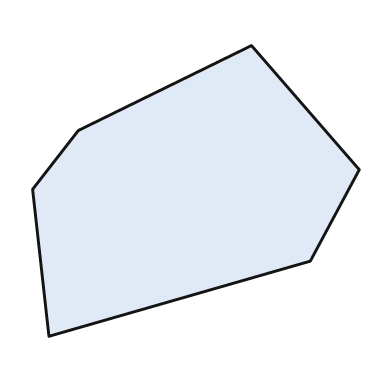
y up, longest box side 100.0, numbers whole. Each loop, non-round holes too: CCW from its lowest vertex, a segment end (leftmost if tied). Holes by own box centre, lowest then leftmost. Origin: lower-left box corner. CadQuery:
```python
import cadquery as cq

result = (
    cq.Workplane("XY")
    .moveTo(5.0, 0.0)
    .lineTo(85.0, 23.0)
    .lineTo(100.0, 51.0)
    .lineTo(67.0, 89.0)
    .lineTo(14.0, 63.0)
    .lineTo(0.0, 45.0)
    .close()
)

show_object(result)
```